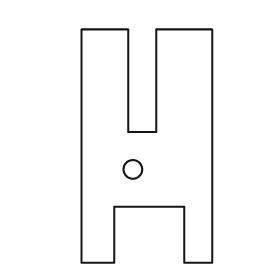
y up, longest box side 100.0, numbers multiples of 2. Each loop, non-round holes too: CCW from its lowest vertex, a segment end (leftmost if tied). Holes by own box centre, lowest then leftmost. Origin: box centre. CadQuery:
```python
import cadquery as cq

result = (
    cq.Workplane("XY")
    .moveTo(-28.0, -50.0)
    .lineTo(-14.0, -50.0)
    .lineTo(-14.0, -26.0)
    .lineTo(16.0, -26.0)
    .lineTo(16.0, -50.0)
    .lineTo(28.0, -50.0)
    .lineTo(28.0, 50.0)
    .lineTo(4.0, 50.0)
    .lineTo(4.0, 6.0)
    .lineTo(-8.0, 6.0)
    .lineTo(-8.0, 50.0)
    .lineTo(-28.0, 50.0)
    .close()
    .moveTo(-6.0, -10.0)
    .circle(4.0)
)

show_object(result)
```